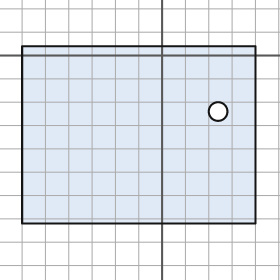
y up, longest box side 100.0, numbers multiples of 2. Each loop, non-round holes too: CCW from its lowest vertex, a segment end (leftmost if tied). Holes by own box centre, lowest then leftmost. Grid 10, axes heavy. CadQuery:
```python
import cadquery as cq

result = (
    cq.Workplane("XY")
    .moveTo(-60.0, -72.0)
    .lineTo(40.0, -72.0)
    .lineTo(40.0, 4.0)
    .lineTo(-60.0, 4.0)
    .close()
    .moveTo(24.0, -24.0)
    .circle(4.0)
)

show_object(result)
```